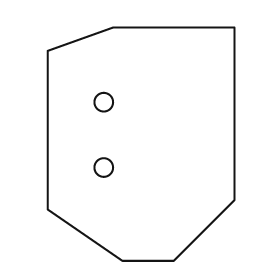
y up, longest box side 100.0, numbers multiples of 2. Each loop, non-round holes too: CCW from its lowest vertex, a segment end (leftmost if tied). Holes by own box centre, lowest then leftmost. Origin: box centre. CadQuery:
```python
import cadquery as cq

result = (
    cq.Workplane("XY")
    .moveTo(-8.0, -50.0)
    .lineTo(14.0, -50.0)
    .lineTo(40.0, -24.0)
    .lineTo(40.0, 50.0)
    .lineTo(-12.0, 50.0)
    .lineTo(-40.0, 40.0)
    .lineTo(-40.0, -28.0)
    .close()
    .moveTo(-16.0, -10.0)
    .circle(4.0)
    .moveTo(-16.0, 18.0)
    .circle(4.0)
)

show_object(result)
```